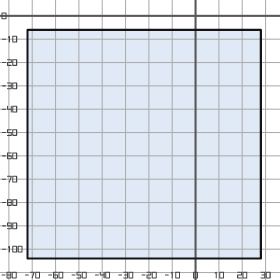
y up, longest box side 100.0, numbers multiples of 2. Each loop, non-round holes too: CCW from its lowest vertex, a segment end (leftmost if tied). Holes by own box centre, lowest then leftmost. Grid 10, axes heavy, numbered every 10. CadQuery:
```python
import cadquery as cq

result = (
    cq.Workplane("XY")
    .moveTo(-72.0, -104.0)
    .lineTo(28.0, -104.0)
    .lineTo(28.0, -6.0)
    .lineTo(-72.0, -6.0)
    .close()
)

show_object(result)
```